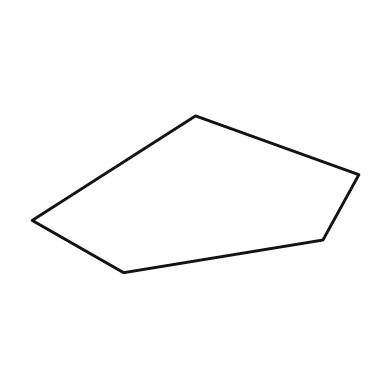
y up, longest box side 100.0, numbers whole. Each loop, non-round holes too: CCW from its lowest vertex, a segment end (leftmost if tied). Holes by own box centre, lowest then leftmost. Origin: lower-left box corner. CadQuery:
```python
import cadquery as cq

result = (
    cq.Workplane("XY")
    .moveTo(28.0, 0.0)
    .lineTo(89.0, 10.0)
    .lineTo(100.0, 30.0)
    .lineTo(50.0, 48.0)
    .lineTo(0.0, 16.0)
    .close()
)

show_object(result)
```